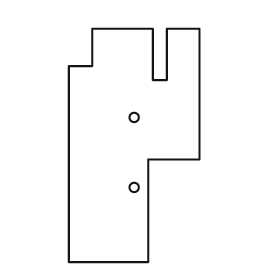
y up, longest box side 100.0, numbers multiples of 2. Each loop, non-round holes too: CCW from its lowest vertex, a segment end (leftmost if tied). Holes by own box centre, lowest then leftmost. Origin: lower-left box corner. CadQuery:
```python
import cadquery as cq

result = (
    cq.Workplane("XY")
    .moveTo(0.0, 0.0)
    .lineTo(34.0, 0.0)
    .lineTo(34.0, 44.0)
    .lineTo(56.0, 44.0)
    .lineTo(56.0, 100.0)
    .lineTo(42.0, 100.0)
    .lineTo(42.0, 78.0)
    .lineTo(36.0, 78.0)
    .lineTo(36.0, 100.0)
    .lineTo(10.0, 100.0)
    .lineTo(10.0, 84.0)
    .lineTo(0.0, 84.0)
    .close()
    .moveTo(28.0, 32.0)
    .circle(2.0)
    .moveTo(28.0, 62.0)
    .circle(2.0)
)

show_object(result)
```